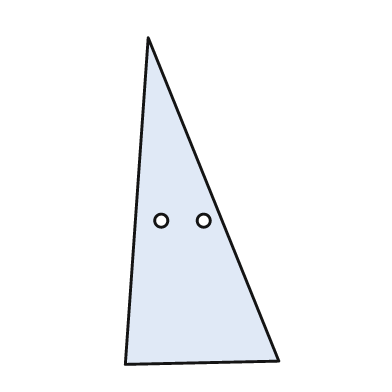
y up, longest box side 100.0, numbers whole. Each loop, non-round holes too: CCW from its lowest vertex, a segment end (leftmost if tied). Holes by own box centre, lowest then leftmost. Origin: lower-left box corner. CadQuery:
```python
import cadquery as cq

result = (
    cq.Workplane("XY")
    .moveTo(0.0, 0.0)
    .lineTo(47.0, 1.0)
    .lineTo(7.0, 100.0)
    .close()
    .moveTo(11.0, 44.0)
    .circle(2.0)
    .moveTo(24.0, 44.0)
    .circle(2.0)
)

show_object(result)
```